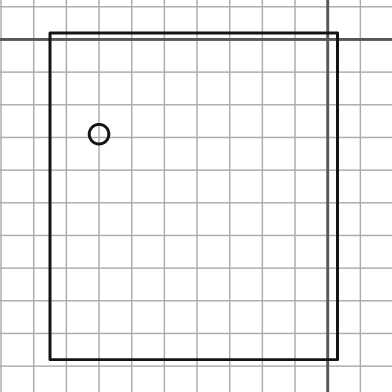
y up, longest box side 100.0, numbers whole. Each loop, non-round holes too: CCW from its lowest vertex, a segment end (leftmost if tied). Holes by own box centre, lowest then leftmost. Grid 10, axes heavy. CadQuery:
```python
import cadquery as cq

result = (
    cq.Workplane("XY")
    .moveTo(-85.0, -98.0)
    .lineTo(3.0, -98.0)
    .lineTo(3.0, 2.0)
    .lineTo(-85.0, 2.0)
    .close()
    .moveTo(-70.0, -29.0)
    .circle(3.0)
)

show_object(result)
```